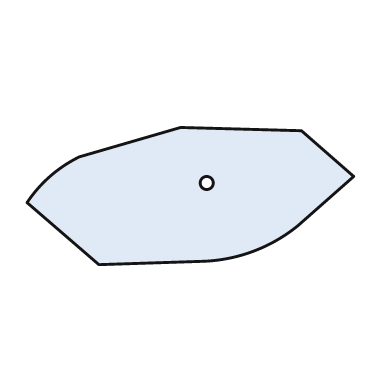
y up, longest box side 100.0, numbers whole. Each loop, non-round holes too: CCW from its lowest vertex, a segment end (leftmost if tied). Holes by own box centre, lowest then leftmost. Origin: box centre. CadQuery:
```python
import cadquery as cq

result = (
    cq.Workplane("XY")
    .moveTo(-28.0, -21.0)
    .lineTo(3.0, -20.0)
    .threePointArc((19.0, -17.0), (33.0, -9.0))
    .lineTo(50.0, 6.0)
    .lineTo(34.0, 20.0)
    .lineTo(-3.0, 21.0)
    .lineTo(-34.0, 12.0)
    .threePointArc((-43.0, 6.0), (-50.0, -2.0))
    .close()
    .moveTo(5.0, 4.0)
    .circle(2.0)
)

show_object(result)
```